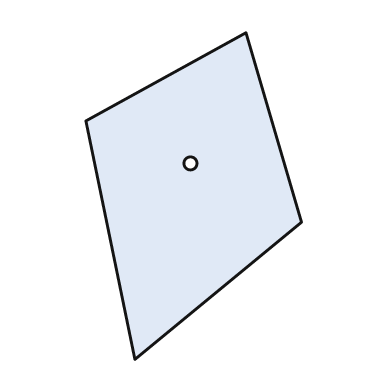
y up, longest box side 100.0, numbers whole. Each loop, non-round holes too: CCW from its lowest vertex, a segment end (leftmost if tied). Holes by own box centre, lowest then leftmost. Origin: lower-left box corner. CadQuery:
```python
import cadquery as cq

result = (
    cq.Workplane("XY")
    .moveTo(15.0, 0.0)
    .lineTo(66.0, 42.0)
    .lineTo(49.0, 100.0)
    .lineTo(0.0, 73.0)
    .close()
    .moveTo(32.0, 60.0)
    .circle(2.0)
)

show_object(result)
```